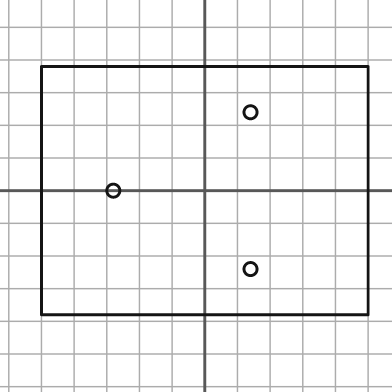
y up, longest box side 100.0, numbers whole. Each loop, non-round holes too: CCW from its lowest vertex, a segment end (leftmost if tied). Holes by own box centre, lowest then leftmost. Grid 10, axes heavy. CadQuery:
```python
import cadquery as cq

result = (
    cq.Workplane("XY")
    .moveTo(-50.0, -38.0)
    .lineTo(50.0, -38.0)
    .lineTo(50.0, 38.0)
    .lineTo(-50.0, 38.0)
    .close()
    .moveTo(14.0, -24.0)
    .circle(2.0)
    .moveTo(-28.0, 0.0)
    .circle(2.0)
    .moveTo(14.0, 24.0)
    .circle(2.0)
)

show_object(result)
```